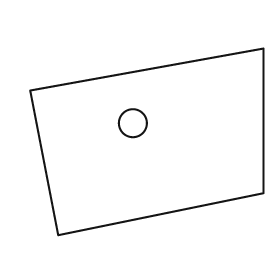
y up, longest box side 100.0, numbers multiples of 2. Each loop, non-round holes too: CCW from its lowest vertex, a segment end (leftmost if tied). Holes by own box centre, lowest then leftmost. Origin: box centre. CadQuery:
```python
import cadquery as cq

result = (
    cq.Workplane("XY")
    .moveTo(-38.0, -40.0)
    .lineTo(50.0, -22.0)
    .lineTo(50.0, 40.0)
    .lineTo(-50.0, 22.0)
    .close()
    .moveTo(-6.0, 8.0)
    .circle(6.0)
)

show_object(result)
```